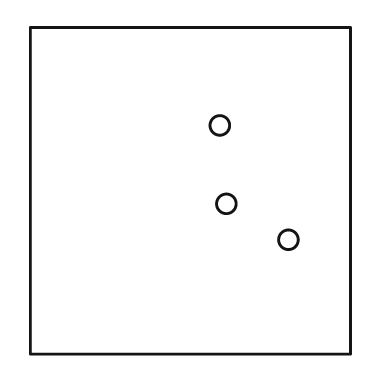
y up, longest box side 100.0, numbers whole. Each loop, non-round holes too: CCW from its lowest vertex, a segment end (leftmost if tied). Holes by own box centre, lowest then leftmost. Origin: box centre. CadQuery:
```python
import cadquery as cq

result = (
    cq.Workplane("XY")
    .moveTo(-49.0, -50.0)
    .lineTo(49.0, -50.0)
    .lineTo(49.0, 50.0)
    .lineTo(-49.0, 50.0)
    .close()
    .moveTo(30.0, -15.0)
    .circle(3.0)
    .moveTo(11.0, -4.0)
    .circle(3.0)
    .moveTo(9.0, 20.0)
    .circle(3.0)
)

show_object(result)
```